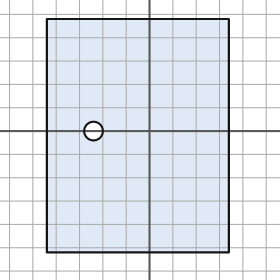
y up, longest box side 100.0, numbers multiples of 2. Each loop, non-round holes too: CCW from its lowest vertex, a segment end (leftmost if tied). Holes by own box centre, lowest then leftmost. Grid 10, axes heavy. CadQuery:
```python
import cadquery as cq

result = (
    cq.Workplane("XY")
    .moveTo(-44.0, -52.0)
    .lineTo(34.0, -52.0)
    .lineTo(34.0, 48.0)
    .lineTo(-44.0, 48.0)
    .close()
    .moveTo(-24.0, 0.0)
    .circle(4.0)
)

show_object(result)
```